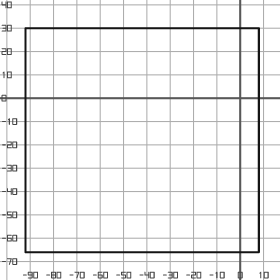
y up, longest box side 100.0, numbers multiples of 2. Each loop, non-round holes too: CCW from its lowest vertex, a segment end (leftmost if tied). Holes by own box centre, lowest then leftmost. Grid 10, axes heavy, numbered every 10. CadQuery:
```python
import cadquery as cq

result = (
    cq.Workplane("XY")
    .moveTo(-92.0, -66.0)
    .lineTo(8.0, -66.0)
    .lineTo(8.0, 30.0)
    .lineTo(-92.0, 30.0)
    .close()
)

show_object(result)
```